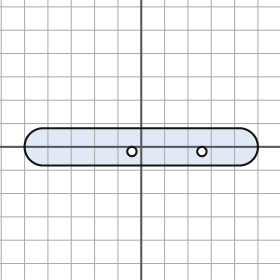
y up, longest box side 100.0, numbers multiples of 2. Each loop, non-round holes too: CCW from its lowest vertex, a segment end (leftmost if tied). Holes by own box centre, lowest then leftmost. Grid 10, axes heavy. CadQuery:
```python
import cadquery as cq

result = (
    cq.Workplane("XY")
    .moveTo(-42.0, -8.0)
    .lineTo(42.0, -8.0)
    .threePointArc((50.0, 0.0), (42.0, 8.0))
    .lineTo(-42.0, 8.0)
    .threePointArc((-50.0, 0.0), (-42.0, -8.0))
    .close()
    .moveTo(-4.0, -2.0)
    .circle(2.0)
    .moveTo(26.0, -2.0)
    .circle(2.0)
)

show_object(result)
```